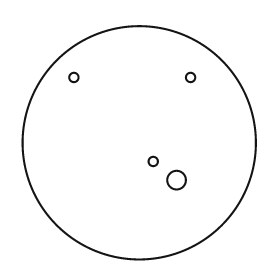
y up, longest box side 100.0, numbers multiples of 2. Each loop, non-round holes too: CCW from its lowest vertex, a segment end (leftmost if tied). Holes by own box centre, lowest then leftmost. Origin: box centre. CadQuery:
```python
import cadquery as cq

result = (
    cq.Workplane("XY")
    .moveTo(0.0, 0.0)
    .circle(50.0)
    .moveTo(16.0, -16.0)
    .circle(4.0)
    .moveTo(6.0, -8.0)
    .circle(2.0)
    .moveTo(-28.0, 28.0)
    .circle(2.0)
    .moveTo(22.0, 28.0)
    .circle(2.0)
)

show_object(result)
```